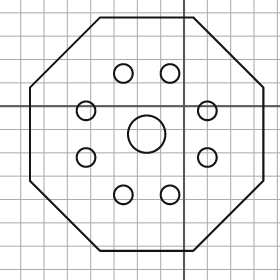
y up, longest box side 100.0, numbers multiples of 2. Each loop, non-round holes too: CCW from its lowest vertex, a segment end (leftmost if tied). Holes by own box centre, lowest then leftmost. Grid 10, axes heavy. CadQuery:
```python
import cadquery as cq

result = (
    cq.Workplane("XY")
    .moveTo(-36.0, -62.0)
    .lineTo(4.0, -62.0)
    .lineTo(34.0, -32.0)
    .lineTo(34.0, 8.0)
    .lineTo(4.0, 38.0)
    .lineTo(-36.0, 38.0)
    .lineTo(-66.0, 8.0)
    .lineTo(-66.0, -32.0)
    .close()
    .moveTo(-26.0, -38.0)
    .circle(4.0)
    .moveTo(-6.0, -38.0)
    .circle(4.0)
    .moveTo(-42.0, -22.0)
    .circle(4.0)
    .moveTo(10.0, -22.0)
    .circle(4.0)
    .moveTo(-16.0, -12.0)
    .circle(8.0)
    .moveTo(-42.0, -2.0)
    .circle(4.0)
    .moveTo(10.0, -2.0)
    .circle(4.0)
    .moveTo(-26.0, 14.0)
    .circle(4.0)
    .moveTo(-6.0, 14.0)
    .circle(4.0)
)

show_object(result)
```